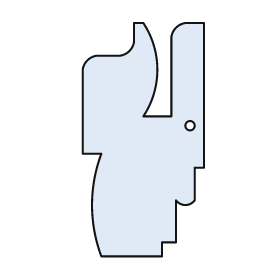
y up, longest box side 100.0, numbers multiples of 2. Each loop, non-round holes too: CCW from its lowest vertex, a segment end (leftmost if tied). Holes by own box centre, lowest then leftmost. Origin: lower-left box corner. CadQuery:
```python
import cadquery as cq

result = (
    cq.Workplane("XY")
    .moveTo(8.0, 0.0)
    .lineTo(34.0, 0.0)
    .lineTo(34.0, 6.0)
    .lineTo(40.0, 6.0)
    .lineTo(40.0, 24.0)
    .threePointArc((44.0, 22.0), (48.0, 24.0))
    .lineTo(48.0, 38.0)
    .lineTo(52.0, 38.0)
    .lineTo(52.0, 100.0)
    .lineTo(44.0, 100.0)
    .threePointArc((40.0, 98.0), (38.0, 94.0))
    .lineTo(38.0, 60.0)
    .lineTo(26.0, 60.0)
    .threePointArc((32.0, 80.0), (26.0, 100.0))
    .lineTo(22.0, 100.0)
    .lineTo(22.0, 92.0)
    .threePointArc((20.0, 88.0), (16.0, 86.0))
    .lineTo(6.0, 86.0)
    .threePointArc((2.0, 84.0), (0.0, 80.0))
    .lineTo(0.0, 44.0)
    .lineTo(8.0, 44.0)
    .threePointArc((4.0, 22.0), (8.0, 0.0))
    .close()
    .moveTo(46.0, 56.0)
    .circle(2.0)
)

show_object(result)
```